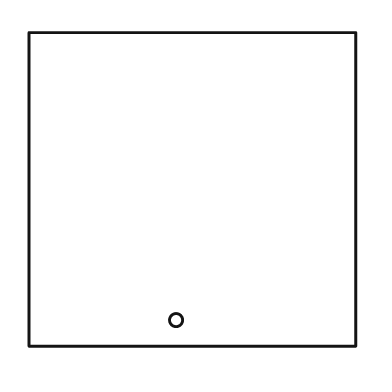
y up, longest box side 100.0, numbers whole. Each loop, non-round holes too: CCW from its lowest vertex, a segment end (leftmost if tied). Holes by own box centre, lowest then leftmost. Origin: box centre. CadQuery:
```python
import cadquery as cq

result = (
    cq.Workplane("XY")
    .moveTo(-50.0, -48.0)
    .lineTo(50.0, -48.0)
    .lineTo(50.0, 48.0)
    .lineTo(-50.0, 48.0)
    .close()
    .moveTo(-5.0, -40.0)
    .circle(2.0)
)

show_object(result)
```